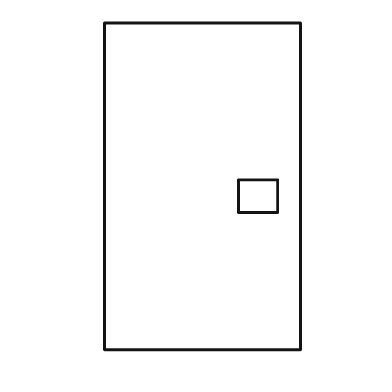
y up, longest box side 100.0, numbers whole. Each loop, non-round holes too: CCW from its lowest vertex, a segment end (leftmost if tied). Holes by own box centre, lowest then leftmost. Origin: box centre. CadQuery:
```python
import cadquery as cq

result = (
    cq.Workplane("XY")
    .moveTo(-30.0, -50.0)
    .lineTo(30.0, -50.0)
    .lineTo(30.0, 50.0)
    .lineTo(-30.0, 50.0)
    .close()
    .moveTo(11.0, -8.0)
    .lineTo(23.0, -8.0)
    .lineTo(23.0, 2.0)
    .lineTo(11.0, 2.0)
    .close()
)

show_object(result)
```